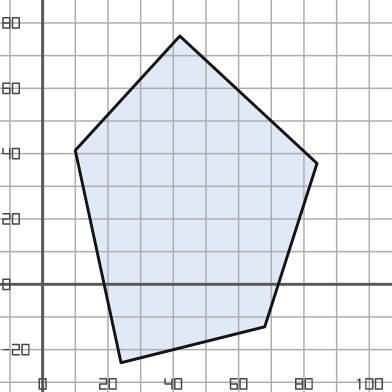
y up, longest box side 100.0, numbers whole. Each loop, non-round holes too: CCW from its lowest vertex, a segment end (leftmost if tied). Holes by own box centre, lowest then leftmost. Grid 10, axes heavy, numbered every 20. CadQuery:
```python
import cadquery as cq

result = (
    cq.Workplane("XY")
    .moveTo(24.0, -24.0)
    .lineTo(68.0, -13.0)
    .lineTo(84.0, 37.0)
    .lineTo(42.0, 76.0)
    .lineTo(10.0, 41.0)
    .close()
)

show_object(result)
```